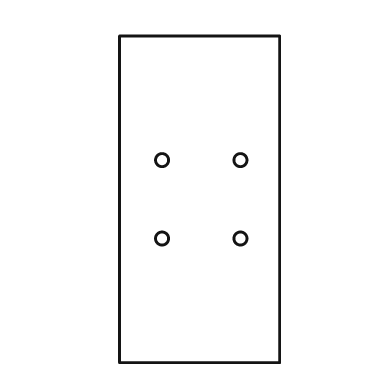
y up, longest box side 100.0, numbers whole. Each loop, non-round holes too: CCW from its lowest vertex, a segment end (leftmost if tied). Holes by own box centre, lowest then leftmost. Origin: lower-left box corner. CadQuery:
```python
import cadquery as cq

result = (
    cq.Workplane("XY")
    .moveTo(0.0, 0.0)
    .lineTo(49.0, 0.0)
    .lineTo(49.0, 100.0)
    .lineTo(0.0, 100.0)
    .close()
    .moveTo(13.0, 38.0)
    .circle(2.0)
    .moveTo(37.0, 38.0)
    .circle(2.0)
    .moveTo(13.0, 62.0)
    .circle(2.0)
    .moveTo(37.0, 62.0)
    .circle(2.0)
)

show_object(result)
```